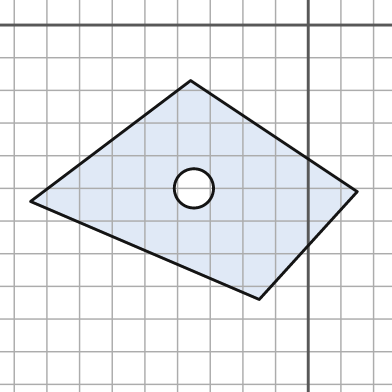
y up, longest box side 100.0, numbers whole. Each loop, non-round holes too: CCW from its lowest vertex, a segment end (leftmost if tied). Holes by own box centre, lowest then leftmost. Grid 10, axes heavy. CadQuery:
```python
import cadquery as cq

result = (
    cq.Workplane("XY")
    .moveTo(-15.0, -84.0)
    .lineTo(15.0, -51.0)
    .lineTo(-36.0, -17.0)
    .lineTo(-85.0, -54.0)
    .close()
    .moveTo(-35.0, -50.0)
    .circle(6.0)
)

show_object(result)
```